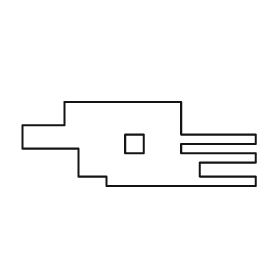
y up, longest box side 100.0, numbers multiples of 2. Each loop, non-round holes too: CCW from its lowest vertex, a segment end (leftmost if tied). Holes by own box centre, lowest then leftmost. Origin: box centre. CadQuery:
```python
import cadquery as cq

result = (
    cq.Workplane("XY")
    .moveTo(-14.0, -18.0)
    .lineTo(50.0, -18.0)
    .lineTo(50.0, -14.0)
    .lineTo(26.0, -14.0)
    .lineTo(26.0, -8.0)
    .lineTo(50.0, -8.0)
    .lineTo(50.0, -4.0)
    .lineTo(18.0, -4.0)
    .lineTo(18.0, 0.0)
    .lineTo(50.0, 0.0)
    .lineTo(50.0, 4.0)
    .lineTo(18.0, 4.0)
    .lineTo(18.0, 18.0)
    .lineTo(-32.0, 18.0)
    .lineTo(-32.0, 8.0)
    .lineTo(-50.0, 8.0)
    .lineTo(-50.0, -2.0)
    .lineTo(-26.0, -2.0)
    .lineTo(-26.0, -14.0)
    .lineTo(-14.0, -14.0)
    .close()
    .moveTo(-6.0, -4.0)
    .lineTo(2.0, -4.0)
    .lineTo(2.0, 4.0)
    .lineTo(-6.0, 4.0)
    .close()
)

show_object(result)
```